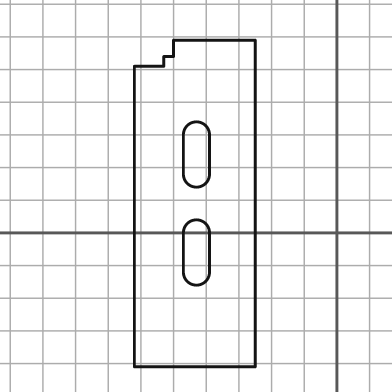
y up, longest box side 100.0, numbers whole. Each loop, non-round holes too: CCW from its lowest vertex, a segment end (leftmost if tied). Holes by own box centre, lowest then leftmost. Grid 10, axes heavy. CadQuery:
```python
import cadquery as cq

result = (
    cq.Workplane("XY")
    .moveTo(-62.0, -41.0)
    .lineTo(-25.0, -41.0)
    .lineTo(-25.0, 59.0)
    .lineTo(-50.0, 59.0)
    .lineTo(-50.0, 54.0)
    .lineTo(-53.0, 54.0)
    .lineTo(-53.0, 51.0)
    .lineTo(-62.0, 51.0)
    .close()
    .moveTo(-47.0, -12.0)
    .threePointArc((-43.0, -16.0), (-39.0, -12.0))
    .lineTo(-39.0, 0.0)
    .threePointArc((-43.0, 4.0), (-47.0, 0.0))
    .close()
    .moveTo(-47.0, 18.0)
    .threePointArc((-43.0, 14.0), (-39.0, 18.0))
    .lineTo(-39.0, 30.0)
    .threePointArc((-43.0, 34.0), (-47.0, 30.0))
    .close()
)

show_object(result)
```